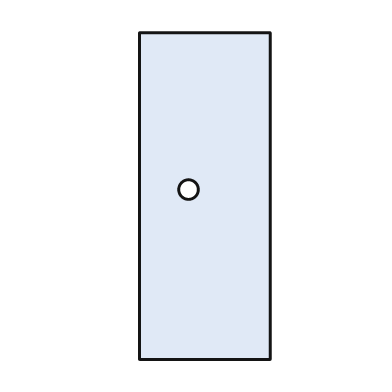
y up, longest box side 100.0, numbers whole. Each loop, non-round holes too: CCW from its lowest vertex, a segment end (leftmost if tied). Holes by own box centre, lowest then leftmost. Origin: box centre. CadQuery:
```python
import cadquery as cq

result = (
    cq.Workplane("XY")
    .moveTo(-20.0, -50.0)
    .lineTo(20.0, -50.0)
    .lineTo(20.0, 50.0)
    .lineTo(-20.0, 50.0)
    .close()
    .moveTo(-5.0, 2.0)
    .circle(3.0)
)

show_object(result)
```